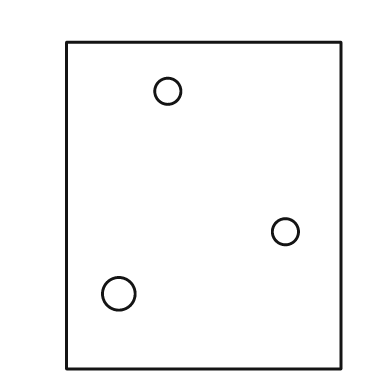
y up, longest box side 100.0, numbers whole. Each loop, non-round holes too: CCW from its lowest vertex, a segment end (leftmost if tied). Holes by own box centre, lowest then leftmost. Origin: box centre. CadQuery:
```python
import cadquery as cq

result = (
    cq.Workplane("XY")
    .moveTo(-42.0, -50.0)
    .lineTo(42.0, -50.0)
    .lineTo(42.0, 50.0)
    .lineTo(-42.0, 50.0)
    .close()
    .moveTo(-26.0, -27.0)
    .circle(5.0)
    .moveTo(25.0, -8.0)
    .circle(4.0)
    .moveTo(-11.0, 35.0)
    .circle(4.0)
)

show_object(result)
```